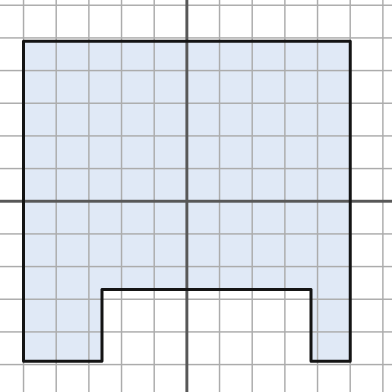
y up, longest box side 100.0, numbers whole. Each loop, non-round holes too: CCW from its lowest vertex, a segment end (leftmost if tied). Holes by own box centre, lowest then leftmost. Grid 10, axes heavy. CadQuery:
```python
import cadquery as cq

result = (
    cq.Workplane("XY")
    .moveTo(-50.0, -49.0)
    .lineTo(-26.0, -49.0)
    .lineTo(-26.0, -27.0)
    .lineTo(38.0, -27.0)
    .lineTo(38.0, -49.0)
    .lineTo(50.0, -49.0)
    .lineTo(50.0, 49.0)
    .lineTo(-50.0, 49.0)
    .close()
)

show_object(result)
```